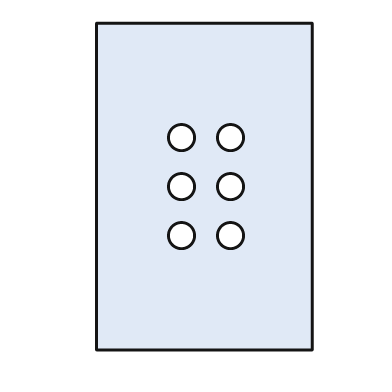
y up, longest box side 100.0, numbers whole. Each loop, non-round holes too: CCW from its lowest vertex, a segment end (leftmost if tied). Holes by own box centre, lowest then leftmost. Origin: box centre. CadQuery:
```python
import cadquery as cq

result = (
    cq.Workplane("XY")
    .moveTo(-33.0, -50.0)
    .lineTo(33.0, -50.0)
    .lineTo(33.0, 50.0)
    .lineTo(-33.0, 50.0)
    .close()
    .moveTo(-7.0, -15.0)
    .circle(4.0)
    .moveTo(8.0, -15.0)
    .circle(4.0)
    .moveTo(-7.0, 0.0)
    .circle(4.0)
    .moveTo(8.0, 0.0)
    .circle(4.0)
    .moveTo(-7.0, 15.0)
    .circle(4.0)
    .moveTo(8.0, 15.0)
    .circle(4.0)
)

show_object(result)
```